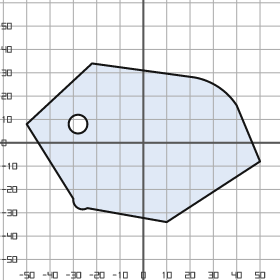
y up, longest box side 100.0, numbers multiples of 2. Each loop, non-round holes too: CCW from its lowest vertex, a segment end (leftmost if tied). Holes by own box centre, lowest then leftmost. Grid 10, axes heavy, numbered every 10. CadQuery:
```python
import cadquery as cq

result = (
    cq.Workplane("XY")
    .moveTo(10.0, -34.0)
    .lineTo(50.0, -8.0)
    .lineTo(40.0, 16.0)
    .threePointArc((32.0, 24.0), (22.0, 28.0))
    .lineTo(-22.0, 34.0)
    .lineTo(-50.0, 8.0)
    .lineTo(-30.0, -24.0)
    .threePointArc((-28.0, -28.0), (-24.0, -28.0))
    .close()
    .moveTo(-28.0, 8.0)
    .circle(4.0)
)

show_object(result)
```